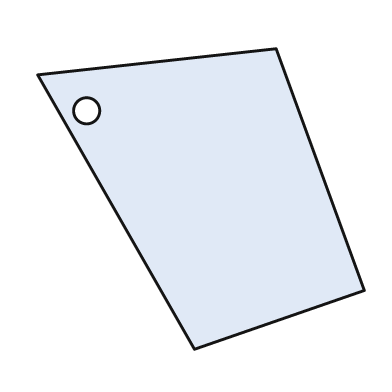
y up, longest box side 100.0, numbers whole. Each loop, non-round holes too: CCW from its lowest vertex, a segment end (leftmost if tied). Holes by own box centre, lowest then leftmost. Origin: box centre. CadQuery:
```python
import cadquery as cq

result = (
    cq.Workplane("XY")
    .moveTo(-2.0, -46.0)
    .lineTo(50.0, -28.0)
    .lineTo(23.0, 46.0)
    .lineTo(-50.0, 38.0)
    .close()
    .moveTo(-35.0, 27.0)
    .circle(4.0)
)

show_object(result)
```